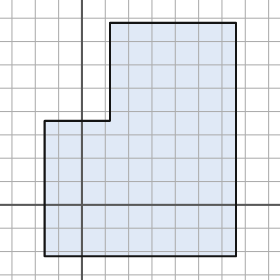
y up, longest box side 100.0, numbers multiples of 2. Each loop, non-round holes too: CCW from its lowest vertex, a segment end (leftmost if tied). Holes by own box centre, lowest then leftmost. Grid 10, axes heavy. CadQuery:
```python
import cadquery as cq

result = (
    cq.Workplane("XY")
    .moveTo(-16.0, -22.0)
    .lineTo(66.0, -22.0)
    .lineTo(66.0, 78.0)
    .lineTo(12.0, 78.0)
    .lineTo(12.0, 36.0)
    .lineTo(-16.0, 36.0)
    .close()
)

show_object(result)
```